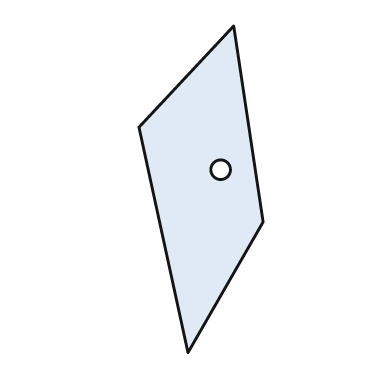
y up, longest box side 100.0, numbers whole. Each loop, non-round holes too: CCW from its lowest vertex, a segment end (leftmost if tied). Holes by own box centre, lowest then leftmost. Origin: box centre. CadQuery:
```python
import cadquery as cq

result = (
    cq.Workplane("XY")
    .moveTo(-4.0, -50.0)
    .lineTo(19.0, -10.0)
    .lineTo(10.0, 50.0)
    .lineTo(-19.0, 19.0)
    .close()
    .moveTo(6.0, 6.0)
    .circle(3.0)
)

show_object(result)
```